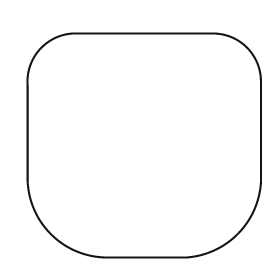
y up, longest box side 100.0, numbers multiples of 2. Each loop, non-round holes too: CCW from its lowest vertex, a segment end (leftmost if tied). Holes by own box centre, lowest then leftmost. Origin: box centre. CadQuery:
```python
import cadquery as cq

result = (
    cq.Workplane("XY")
    .moveTo(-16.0, -48.0)
    .lineTo(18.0, -48.0)
    .threePointArc((40.0, -38.0), (50.0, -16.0))
    .lineTo(50.0, 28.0)
    .threePointArc((44.0, 42.0), (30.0, 48.0))
    .lineTo(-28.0, 48.0)
    .threePointArc((-44.0, 42.0), (-50.0, 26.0))
    .lineTo(-50.0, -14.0)
    .threePointArc((-40.0, -38.0), (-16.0, -48.0))
    .close()
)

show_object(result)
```